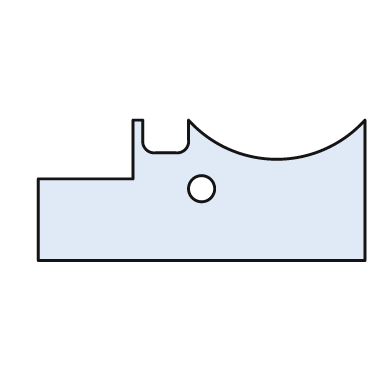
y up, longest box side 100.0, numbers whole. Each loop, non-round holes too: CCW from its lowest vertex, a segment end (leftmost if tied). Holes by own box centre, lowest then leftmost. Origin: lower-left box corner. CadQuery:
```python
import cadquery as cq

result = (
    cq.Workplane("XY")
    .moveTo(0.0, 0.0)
    .lineTo(100.0, 0.0)
    .lineTo(100.0, 43.0)
    .threePointArc((73.0, 31.0), (46.0, 43.0))
    .lineTo(46.0, 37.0)
    .threePointArc((45.0, 34.0), (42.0, 33.0))
    .lineTo(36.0, 33.0)
    .threePointArc((33.0, 34.0), (32.0, 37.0))
    .lineTo(32.0, 43.0)
    .lineTo(29.0, 43.0)
    .lineTo(29.0, 25.0)
    .lineTo(0.0, 25.0)
    .close()
    .moveTo(50.0, 22.0)
    .circle(4.0)
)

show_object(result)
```